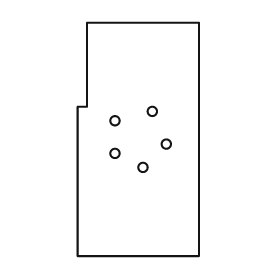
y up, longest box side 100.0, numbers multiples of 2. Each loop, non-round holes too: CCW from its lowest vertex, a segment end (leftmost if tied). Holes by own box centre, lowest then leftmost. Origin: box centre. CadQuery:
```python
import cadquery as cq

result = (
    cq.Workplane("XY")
    .moveTo(-26.0, -50.0)
    .lineTo(26.0, -50.0)
    .lineTo(26.0, 50.0)
    .lineTo(-22.0, 50.0)
    .lineTo(-22.0, 14.0)
    .lineTo(-26.0, 14.0)
    .close()
    .moveTo(2.0, -12.0)
    .circle(2.0)
    .moveTo(-10.0, -6.0)
    .circle(2.0)
    .moveTo(12.0, -2.0)
    .circle(2.0)
    .moveTo(-10.0, 8.0)
    .circle(2.0)
    .moveTo(6.0, 12.0)
    .circle(2.0)
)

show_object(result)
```